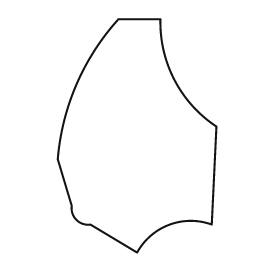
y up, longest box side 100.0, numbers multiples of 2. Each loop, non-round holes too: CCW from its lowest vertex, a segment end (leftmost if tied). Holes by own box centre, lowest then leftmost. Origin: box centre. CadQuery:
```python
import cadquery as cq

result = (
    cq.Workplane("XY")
    .moveTo(0.0, -50.0)
    .threePointArc((14.0, -38.0), (32.0, -38.0))
    .lineTo(34.0, 4.0)
    .threePointArc((16.0, 24.0), (10.0, 50.0))
    .lineTo(-8.0, 50.0)
    .threePointArc((-26.0, 22.0), (-34.0, -10.0))
    .lineTo(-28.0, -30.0)
    .threePointArc((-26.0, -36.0), (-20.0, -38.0))
    .close()
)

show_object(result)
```